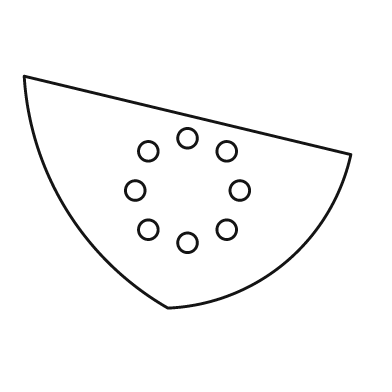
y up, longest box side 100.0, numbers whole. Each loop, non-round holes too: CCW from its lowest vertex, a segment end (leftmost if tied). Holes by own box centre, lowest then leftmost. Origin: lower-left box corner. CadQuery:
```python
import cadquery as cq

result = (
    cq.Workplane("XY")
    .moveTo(44.0, 0.0)
    .threePointArc((80.0, 14.0), (100.0, 47.0))
    .lineTo(0.0, 71.0)
    .threePointArc((13.0, 30.0), (44.0, 0.0))
    .close()
    .moveTo(50.0, 20.0)
    .circle(3.0)
    .moveTo(38.0, 24.0)
    .circle(3.0)
    .moveTo(62.0, 24.0)
    .circle(3.0)
    .moveTo(34.0, 36.0)
    .circle(3.0)
    .moveTo(66.0, 36.0)
    .circle(3.0)
    .moveTo(38.0, 48.0)
    .circle(3.0)
    .moveTo(62.0, 48.0)
    .circle(3.0)
    .moveTo(50.0, 52.0)
    .circle(3.0)
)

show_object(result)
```